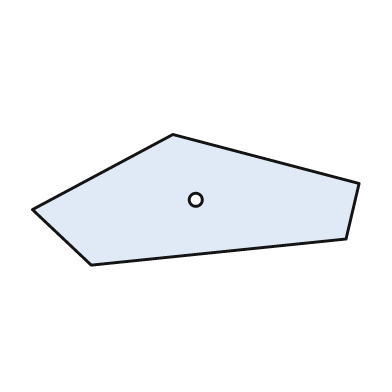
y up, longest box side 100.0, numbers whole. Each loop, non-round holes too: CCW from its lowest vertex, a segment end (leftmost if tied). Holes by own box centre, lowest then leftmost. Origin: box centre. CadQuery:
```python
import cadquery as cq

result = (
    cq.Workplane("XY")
    .moveTo(-32.0, -20.0)
    .lineTo(46.0, -12.0)
    .lineTo(50.0, 5.0)
    .lineTo(-7.0, 20.0)
    .lineTo(-50.0, -3.0)
    .close()
    .moveTo(0.0, 0.0)
    .circle(2.0)
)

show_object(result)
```